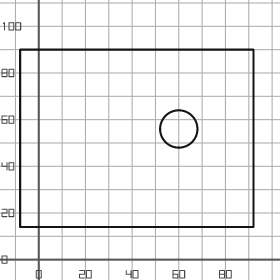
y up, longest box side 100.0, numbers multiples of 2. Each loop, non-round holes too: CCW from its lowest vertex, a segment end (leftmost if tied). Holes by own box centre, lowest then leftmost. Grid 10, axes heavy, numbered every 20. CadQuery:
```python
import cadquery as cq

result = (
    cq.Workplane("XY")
    .moveTo(-8.0, 14.0)
    .lineTo(92.0, 14.0)
    .lineTo(92.0, 90.0)
    .lineTo(-8.0, 90.0)
    .close()
    .moveTo(60.0, 56.0)
    .circle(8.0)
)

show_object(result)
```